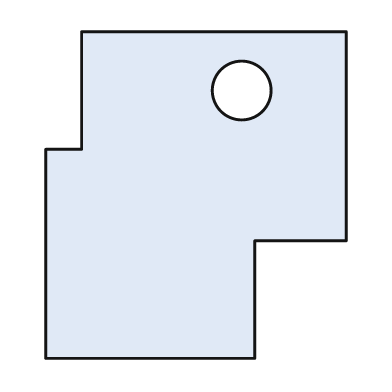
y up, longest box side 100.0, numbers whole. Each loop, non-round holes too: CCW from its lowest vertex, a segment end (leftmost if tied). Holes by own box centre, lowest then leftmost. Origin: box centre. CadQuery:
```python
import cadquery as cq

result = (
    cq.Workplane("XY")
    .moveTo(-46.0, -50.0)
    .lineTo(18.0, -50.0)
    .lineTo(18.0, -14.0)
    .lineTo(46.0, -14.0)
    .lineTo(46.0, 50.0)
    .lineTo(-35.0, 50.0)
    .lineTo(-35.0, 14.0)
    .lineTo(-46.0, 14.0)
    .close()
    .moveTo(14.0, 32.0)
    .circle(9.0)
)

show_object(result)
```